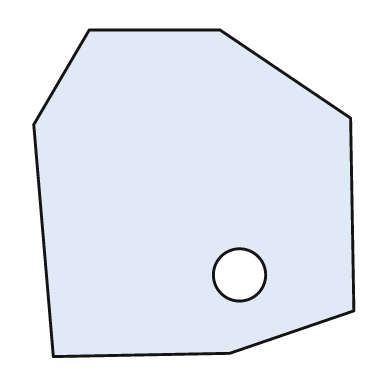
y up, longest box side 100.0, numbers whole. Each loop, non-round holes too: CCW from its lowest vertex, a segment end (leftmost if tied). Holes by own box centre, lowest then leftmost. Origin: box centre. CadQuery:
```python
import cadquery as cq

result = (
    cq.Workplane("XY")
    .moveTo(-43.0, -50.0)
    .lineTo(11.0, -49.0)
    .lineTo(49.0, -36.0)
    .lineTo(48.0, 23.0)
    .lineTo(8.0, 50.0)
    .lineTo(-32.0, 50.0)
    .lineTo(-49.0, 21.0)
    .close()
    .moveTo(14.0, -25.0)
    .circle(8.0)
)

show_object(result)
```